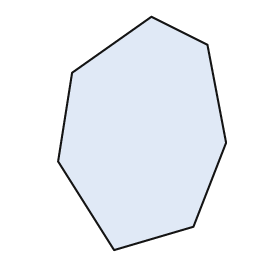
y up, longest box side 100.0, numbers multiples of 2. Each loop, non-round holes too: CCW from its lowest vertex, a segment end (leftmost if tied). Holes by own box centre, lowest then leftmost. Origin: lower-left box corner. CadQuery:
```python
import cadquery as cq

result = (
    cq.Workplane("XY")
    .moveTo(24.0, 0.0)
    .lineTo(58.0, 10.0)
    .lineTo(72.0, 46.0)
    .lineTo(64.0, 88.0)
    .lineTo(40.0, 100.0)
    .lineTo(6.0, 76.0)
    .lineTo(0.0, 38.0)
    .close()
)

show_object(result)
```